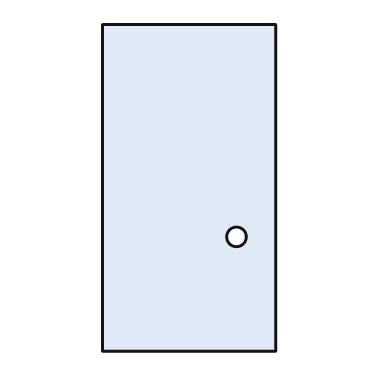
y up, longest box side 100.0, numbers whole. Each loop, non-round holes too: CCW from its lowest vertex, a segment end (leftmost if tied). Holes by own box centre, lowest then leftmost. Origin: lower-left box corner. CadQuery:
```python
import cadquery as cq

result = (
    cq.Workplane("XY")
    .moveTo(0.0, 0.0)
    .lineTo(53.0, 0.0)
    .lineTo(53.0, 100.0)
    .lineTo(0.0, 100.0)
    .close()
    .moveTo(41.0, 35.0)
    .circle(3.0)
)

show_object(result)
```